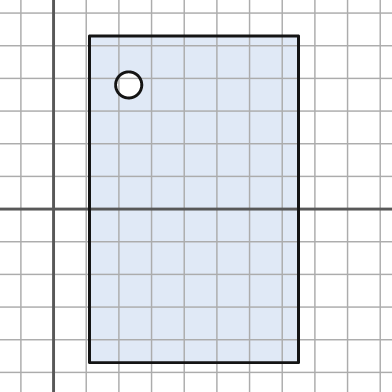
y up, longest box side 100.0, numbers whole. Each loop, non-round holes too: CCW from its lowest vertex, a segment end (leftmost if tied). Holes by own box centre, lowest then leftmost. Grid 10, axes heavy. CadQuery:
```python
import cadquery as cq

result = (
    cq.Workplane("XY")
    .moveTo(11.0, -47.0)
    .lineTo(75.0, -47.0)
    .lineTo(75.0, 53.0)
    .lineTo(11.0, 53.0)
    .close()
    .moveTo(23.0, 38.0)
    .circle(4.0)
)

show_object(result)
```